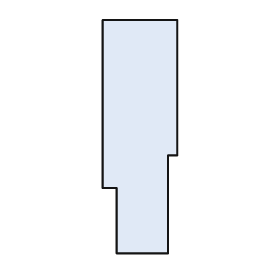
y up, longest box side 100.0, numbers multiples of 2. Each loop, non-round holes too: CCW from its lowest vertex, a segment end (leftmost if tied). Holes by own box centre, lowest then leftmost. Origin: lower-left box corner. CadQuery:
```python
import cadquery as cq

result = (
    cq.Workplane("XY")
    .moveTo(6.0, 0.0)
    .lineTo(28.0, 0.0)
    .lineTo(28.0, 42.0)
    .lineTo(32.0, 42.0)
    .lineTo(32.0, 100.0)
    .lineTo(0.0, 100.0)
    .lineTo(0.0, 28.0)
    .lineTo(6.0, 28.0)
    .close()
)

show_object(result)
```